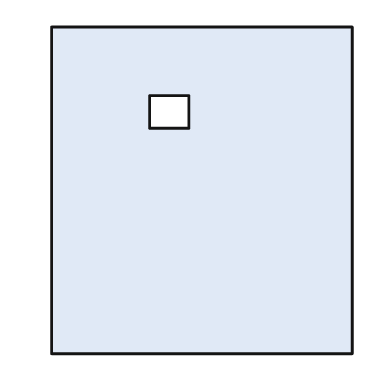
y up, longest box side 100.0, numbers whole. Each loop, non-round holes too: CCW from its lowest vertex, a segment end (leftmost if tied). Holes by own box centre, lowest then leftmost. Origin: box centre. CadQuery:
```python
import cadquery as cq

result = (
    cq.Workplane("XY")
    .moveTo(-46.0, -50.0)
    .lineTo(46.0, -50.0)
    .lineTo(46.0, 50.0)
    .lineTo(-46.0, 50.0)
    .close()
    .moveTo(-16.0, 19.0)
    .lineTo(-4.0, 19.0)
    .lineTo(-4.0, 29.0)
    .lineTo(-16.0, 29.0)
    .close()
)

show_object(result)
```